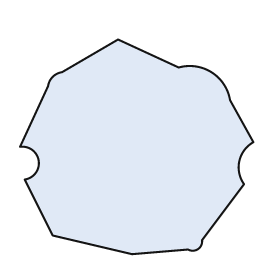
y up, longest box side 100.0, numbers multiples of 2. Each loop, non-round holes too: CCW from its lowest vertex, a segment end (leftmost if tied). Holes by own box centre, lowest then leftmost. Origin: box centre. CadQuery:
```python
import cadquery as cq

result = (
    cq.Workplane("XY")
    .moveTo(-2.0, -46.0)
    .lineTo(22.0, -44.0)
    .threePointArc((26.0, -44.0), (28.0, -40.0))
    .lineTo(46.0, -16.0)
    .threePointArc((44.0, -6.0), (50.0, 2.0))
    .lineTo(40.0, 20.0)
    .threePointArc((32.0, 32.0), (18.0, 34.0))
    .lineTo(-8.0, 46.0)
    .lineTo(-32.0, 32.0)
    .threePointArc((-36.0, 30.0), (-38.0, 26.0))
    .lineTo(-50.0, 0.0)
    .threePointArc((-42.0, -6.0), (-48.0, -14.0))
    .lineTo(-36.0, -38.0)
    .close()
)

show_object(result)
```